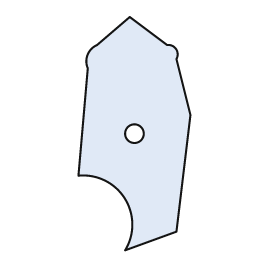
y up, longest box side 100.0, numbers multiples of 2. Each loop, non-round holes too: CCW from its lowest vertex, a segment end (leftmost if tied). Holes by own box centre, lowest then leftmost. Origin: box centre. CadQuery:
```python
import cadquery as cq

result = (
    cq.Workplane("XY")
    .moveTo(-4.0, -50.0)
    .lineTo(18.0, -42.0)
    .lineTo(24.0, 8.0)
    .lineTo(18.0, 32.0)
    .threePointArc((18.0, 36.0), (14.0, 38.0))
    .lineTo(-2.0, 50.0)
    .lineTo(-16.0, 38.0)
    .threePointArc((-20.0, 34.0), (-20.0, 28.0))
    .lineTo(-24.0, -18.0)
    .threePointArc((-4.0, -28.0), (-4.0, -50.0))
    .close()
    .moveTo(0.0, 0.0)
    .circle(4.0)
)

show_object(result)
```